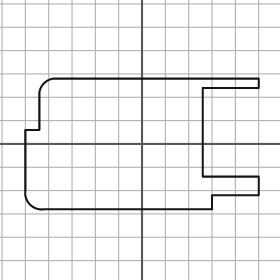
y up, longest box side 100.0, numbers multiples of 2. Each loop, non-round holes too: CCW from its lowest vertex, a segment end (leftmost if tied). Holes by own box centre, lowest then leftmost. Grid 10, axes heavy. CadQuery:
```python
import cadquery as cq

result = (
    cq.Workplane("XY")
    .moveTo(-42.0, -28.0)
    .lineTo(30.0, -28.0)
    .lineTo(30.0, -22.0)
    .lineTo(50.0, -22.0)
    .lineTo(50.0, -14.0)
    .lineTo(26.0, -14.0)
    .lineTo(26.0, 24.0)
    .lineTo(50.0, 24.0)
    .lineTo(50.0, 28.0)
    .lineTo(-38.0, 28.0)
    .threePointArc((-42.0, 26.0), (-44.0, 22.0))
    .lineTo(-44.0, 6.0)
    .lineTo(-50.0, 6.0)
    .lineTo(-50.0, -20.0)
    .threePointArc((-48.0, -26.0), (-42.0, -28.0))
    .close()
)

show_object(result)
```